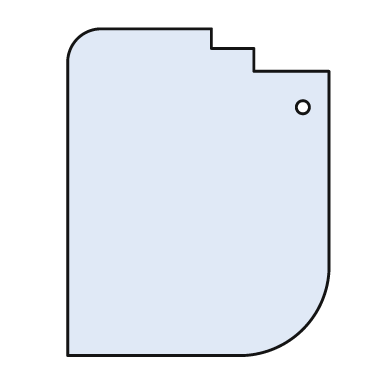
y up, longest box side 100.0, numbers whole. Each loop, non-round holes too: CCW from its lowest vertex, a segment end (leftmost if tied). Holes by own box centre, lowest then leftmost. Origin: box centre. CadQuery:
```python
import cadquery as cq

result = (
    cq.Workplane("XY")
    .moveTo(-40.0, -50.0)
    .lineTo(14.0, -50.0)
    .threePointArc((32.0, -42.0), (40.0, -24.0))
    .lineTo(40.0, 37.0)
    .lineTo(17.0, 37.0)
    .lineTo(17.0, 44.0)
    .lineTo(4.0, 44.0)
    .lineTo(4.0, 50.0)
    .lineTo(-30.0, 50.0)
    .threePointArc((-37.0, 47.0), (-40.0, 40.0))
    .close()
    .moveTo(32.0, 26.0)
    .circle(2.0)
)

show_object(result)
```